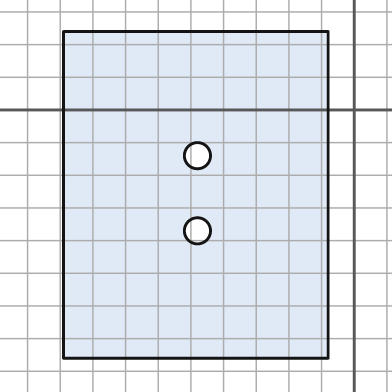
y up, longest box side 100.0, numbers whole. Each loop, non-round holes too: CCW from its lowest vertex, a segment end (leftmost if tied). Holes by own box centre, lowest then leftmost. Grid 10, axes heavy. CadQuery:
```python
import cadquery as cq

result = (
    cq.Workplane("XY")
    .moveTo(-89.0, -76.0)
    .lineTo(-8.0, -76.0)
    .lineTo(-8.0, 24.0)
    .lineTo(-89.0, 24.0)
    .close()
    .moveTo(-48.0, -37.0)
    .circle(4.0)
    .moveTo(-48.0, -14.0)
    .circle(4.0)
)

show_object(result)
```